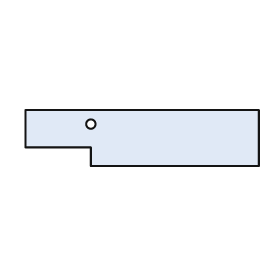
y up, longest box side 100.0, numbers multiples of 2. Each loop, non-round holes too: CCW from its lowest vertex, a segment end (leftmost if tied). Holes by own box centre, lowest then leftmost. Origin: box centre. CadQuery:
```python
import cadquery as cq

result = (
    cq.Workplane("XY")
    .moveTo(-22.0, -12.0)
    .lineTo(50.0, -12.0)
    .lineTo(50.0, 12.0)
    .lineTo(-50.0, 12.0)
    .lineTo(-50.0, -4.0)
    .lineTo(-22.0, -4.0)
    .close()
    .moveTo(-22.0, 6.0)
    .circle(2.0)
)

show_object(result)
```